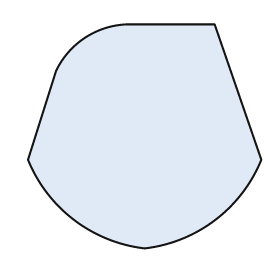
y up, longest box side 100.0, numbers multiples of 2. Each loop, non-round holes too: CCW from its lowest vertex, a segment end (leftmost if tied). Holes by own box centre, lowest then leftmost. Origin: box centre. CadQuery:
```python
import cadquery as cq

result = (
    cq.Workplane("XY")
    .moveTo(0.0, -48.0)
    .threePointArc((30.0, -36.0), (50.0, -10.0))
    .lineTo(30.0, 48.0)
    .lineTo(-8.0, 48.0)
    .threePointArc((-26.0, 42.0), (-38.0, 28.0))
    .lineTo(-50.0, -10.0)
    .threePointArc((-30.0, -36.0), (0.0, -48.0))
    .close()
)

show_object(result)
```